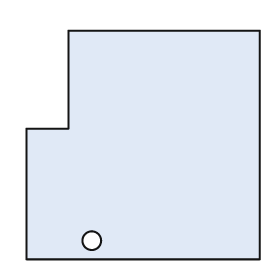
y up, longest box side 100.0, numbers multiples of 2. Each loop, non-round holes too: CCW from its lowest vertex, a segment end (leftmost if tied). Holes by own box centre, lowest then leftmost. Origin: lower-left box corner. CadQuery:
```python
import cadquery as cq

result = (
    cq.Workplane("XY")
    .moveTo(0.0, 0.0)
    .lineTo(100.0, 0.0)
    .lineTo(100.0, 98.0)
    .lineTo(18.0, 98.0)
    .lineTo(18.0, 56.0)
    .lineTo(0.0, 56.0)
    .close()
    .moveTo(28.0, 8.0)
    .circle(4.0)
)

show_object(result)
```